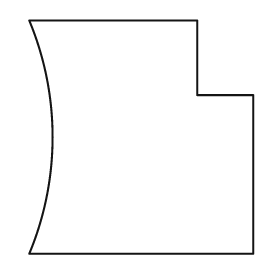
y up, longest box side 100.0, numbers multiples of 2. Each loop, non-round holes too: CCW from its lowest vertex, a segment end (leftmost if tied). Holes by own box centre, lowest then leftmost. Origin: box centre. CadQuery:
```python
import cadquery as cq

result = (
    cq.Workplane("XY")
    .moveTo(-48.0, -50.0)
    .lineTo(48.0, -50.0)
    .lineTo(48.0, 18.0)
    .lineTo(24.0, 18.0)
    .lineTo(24.0, 50.0)
    .lineTo(-48.0, 50.0)
    .threePointArc((-38.0, 0.0), (-48.0, -50.0))
    .close()
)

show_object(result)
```